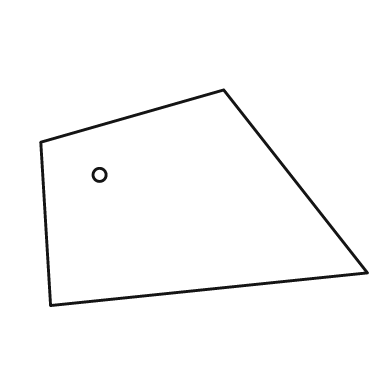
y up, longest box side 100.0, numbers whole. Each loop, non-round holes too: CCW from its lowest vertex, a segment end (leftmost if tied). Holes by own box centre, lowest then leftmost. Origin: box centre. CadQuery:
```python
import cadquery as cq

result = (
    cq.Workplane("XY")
    .moveTo(-47.0, -33.0)
    .lineTo(50.0, -23.0)
    .lineTo(6.0, 33.0)
    .lineTo(-50.0, 17.0)
    .close()
    .moveTo(-32.0, 7.0)
    .circle(2.0)
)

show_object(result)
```